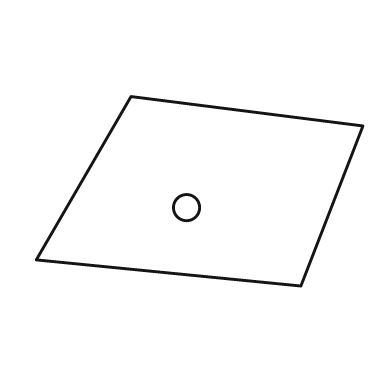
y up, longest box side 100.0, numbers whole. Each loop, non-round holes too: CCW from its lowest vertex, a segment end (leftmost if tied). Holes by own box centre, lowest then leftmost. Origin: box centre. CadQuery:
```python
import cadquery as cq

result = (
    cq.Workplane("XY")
    .moveTo(31.0, -29.0)
    .lineTo(50.0, 20.0)
    .lineTo(-21.0, 29.0)
    .lineTo(-50.0, -21.0)
    .close()
    .moveTo(-4.0, -5.0)
    .circle(4.0)
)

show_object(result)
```